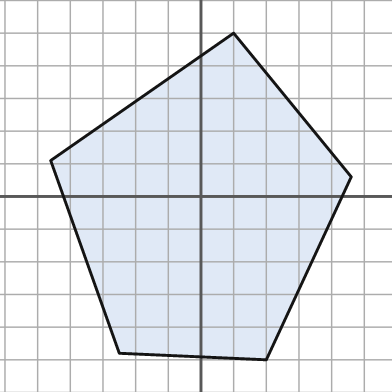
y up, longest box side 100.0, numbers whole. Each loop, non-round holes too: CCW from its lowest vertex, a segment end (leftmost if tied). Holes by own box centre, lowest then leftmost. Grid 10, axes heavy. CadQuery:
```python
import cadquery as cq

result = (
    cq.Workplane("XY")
    .moveTo(20.0, -50.0)
    .lineTo(46.0, 6.0)
    .lineTo(10.0, 50.0)
    .lineTo(-46.0, 11.0)
    .lineTo(-25.0, -48.0)
    .close()
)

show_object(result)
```